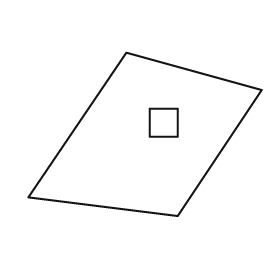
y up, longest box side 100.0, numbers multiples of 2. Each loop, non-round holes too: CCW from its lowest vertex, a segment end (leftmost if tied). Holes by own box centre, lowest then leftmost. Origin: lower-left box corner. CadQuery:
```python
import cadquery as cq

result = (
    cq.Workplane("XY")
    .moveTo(64.0, 0.0)
    .lineTo(100.0, 54.0)
    .lineTo(42.0, 70.0)
    .lineTo(0.0, 8.0)
    .close()
    .moveTo(52.0, 34.0)
    .lineTo(64.0, 34.0)
    .lineTo(64.0, 46.0)
    .lineTo(52.0, 46.0)
    .close()
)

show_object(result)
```